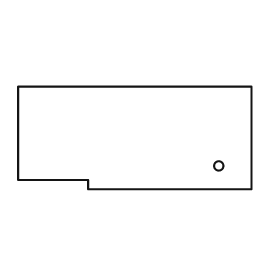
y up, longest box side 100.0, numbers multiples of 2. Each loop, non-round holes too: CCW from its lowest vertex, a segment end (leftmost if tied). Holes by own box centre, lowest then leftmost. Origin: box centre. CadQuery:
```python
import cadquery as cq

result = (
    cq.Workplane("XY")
    .moveTo(-20.0, -22.0)
    .lineTo(50.0, -22.0)
    .lineTo(50.0, 22.0)
    .lineTo(-50.0, 22.0)
    .lineTo(-50.0, -18.0)
    .lineTo(-20.0, -18.0)
    .close()
    .moveTo(36.0, -12.0)
    .circle(2.0)
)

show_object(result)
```